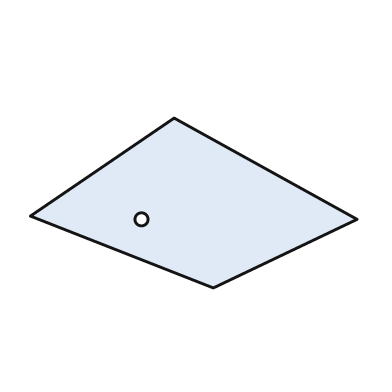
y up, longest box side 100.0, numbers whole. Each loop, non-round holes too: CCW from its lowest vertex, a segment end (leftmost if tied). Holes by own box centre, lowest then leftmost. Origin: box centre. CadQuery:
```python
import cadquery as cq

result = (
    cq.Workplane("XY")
    .moveTo(6.0, -26.0)
    .lineTo(50.0, -5.0)
    .lineTo(-6.0, 26.0)
    .lineTo(-50.0, -4.0)
    .close()
    .moveTo(-16.0, -5.0)
    .circle(2.0)
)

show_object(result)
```